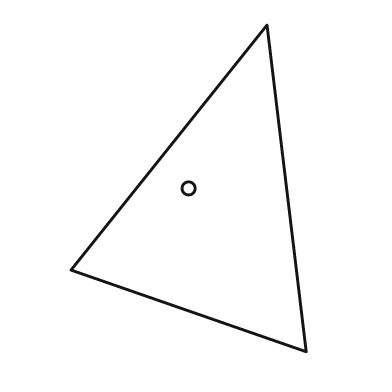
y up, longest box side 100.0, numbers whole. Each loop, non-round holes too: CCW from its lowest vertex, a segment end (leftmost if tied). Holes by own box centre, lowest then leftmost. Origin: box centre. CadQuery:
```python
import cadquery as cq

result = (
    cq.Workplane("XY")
    .moveTo(36.0, -50.0)
    .lineTo(24.0, 50.0)
    .lineTo(-36.0, -25.0)
    .close()
    .moveTo(0.0, 0.0)
    .circle(2.0)
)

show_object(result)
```